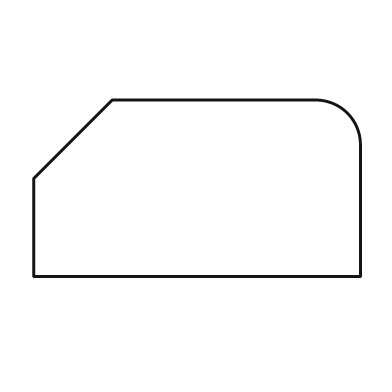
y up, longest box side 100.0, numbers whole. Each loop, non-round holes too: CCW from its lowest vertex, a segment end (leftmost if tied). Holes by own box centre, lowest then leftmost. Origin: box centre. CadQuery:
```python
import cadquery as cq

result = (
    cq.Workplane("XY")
    .moveTo(-50.0, -27.0)
    .lineTo(50.0, -27.0)
    .lineTo(50.0, 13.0)
    .threePointArc((46.0, 23.0), (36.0, 27.0))
    .lineTo(-26.0, 27.0)
    .lineTo(-50.0, 3.0)
    .close()
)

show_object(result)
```